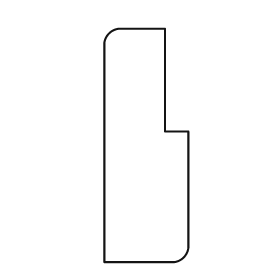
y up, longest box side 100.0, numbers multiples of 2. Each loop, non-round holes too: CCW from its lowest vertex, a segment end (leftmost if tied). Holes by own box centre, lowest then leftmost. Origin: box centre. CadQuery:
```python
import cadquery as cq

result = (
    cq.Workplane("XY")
    .moveTo(-18.0, -50.0)
    .lineTo(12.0, -50.0)
    .threePointArc((16.0, -48.0), (18.0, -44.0))
    .lineTo(18.0, 6.0)
    .lineTo(8.0, 6.0)
    .lineTo(8.0, 50.0)
    .lineTo(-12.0, 50.0)
    .threePointArc((-16.0, 48.0), (-18.0, 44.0))
    .close()
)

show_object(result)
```